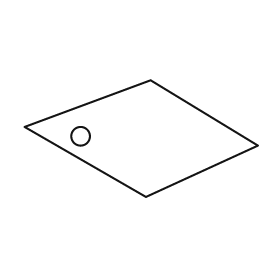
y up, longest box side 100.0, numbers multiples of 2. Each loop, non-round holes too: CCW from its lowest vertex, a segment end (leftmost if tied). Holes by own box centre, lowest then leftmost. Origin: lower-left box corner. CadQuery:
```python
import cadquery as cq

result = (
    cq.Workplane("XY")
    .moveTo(52.0, 0.0)
    .lineTo(100.0, 22.0)
    .lineTo(54.0, 50.0)
    .lineTo(0.0, 30.0)
    .close()
    .moveTo(24.0, 26.0)
    .circle(4.0)
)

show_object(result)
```